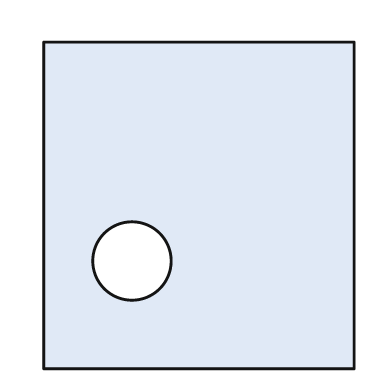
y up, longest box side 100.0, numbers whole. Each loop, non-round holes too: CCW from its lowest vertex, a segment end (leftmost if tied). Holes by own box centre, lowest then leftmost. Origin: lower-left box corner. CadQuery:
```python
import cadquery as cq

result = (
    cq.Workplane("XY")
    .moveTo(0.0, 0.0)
    .lineTo(95.0, 0.0)
    .lineTo(95.0, 100.0)
    .lineTo(0.0, 100.0)
    .close()
    .moveTo(27.0, 33.0)
    .circle(12.0)
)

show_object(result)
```